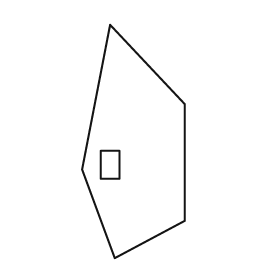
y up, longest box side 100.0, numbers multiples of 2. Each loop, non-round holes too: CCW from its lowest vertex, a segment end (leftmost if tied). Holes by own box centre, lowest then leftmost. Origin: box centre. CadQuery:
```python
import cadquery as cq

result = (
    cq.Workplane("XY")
    .moveTo(-8.0, -50.0)
    .lineTo(22.0, -34.0)
    .lineTo(22.0, 16.0)
    .lineTo(-10.0, 50.0)
    .lineTo(-22.0, -12.0)
    .close()
    .moveTo(-14.0, -16.0)
    .lineTo(-6.0, -16.0)
    .lineTo(-6.0, -4.0)
    .lineTo(-14.0, -4.0)
    .close()
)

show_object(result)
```